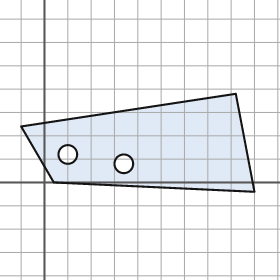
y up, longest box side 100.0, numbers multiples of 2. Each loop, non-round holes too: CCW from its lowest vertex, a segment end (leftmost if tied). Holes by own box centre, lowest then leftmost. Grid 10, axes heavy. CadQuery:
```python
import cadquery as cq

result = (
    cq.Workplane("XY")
    .moveTo(90.0, -4.0)
    .lineTo(82.0, 38.0)
    .lineTo(-10.0, 24.0)
    .lineTo(4.0, 0.0)
    .close()
    .moveTo(34.0, 8.0)
    .circle(4.0)
    .moveTo(10.0, 12.0)
    .circle(4.0)
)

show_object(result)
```